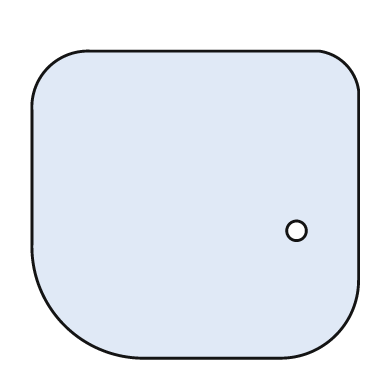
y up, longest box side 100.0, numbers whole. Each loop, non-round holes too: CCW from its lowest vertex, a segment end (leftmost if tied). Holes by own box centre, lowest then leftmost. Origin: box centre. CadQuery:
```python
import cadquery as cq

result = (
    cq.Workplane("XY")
    .moveTo(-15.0, -47.0)
    .lineTo(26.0, -47.0)
    .threePointArc((43.0, -40.0), (50.0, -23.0))
    .lineTo(50.0, 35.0)
    .threePointArc((46.0, 43.0), (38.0, 47.0))
    .lineTo(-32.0, 47.0)
    .threePointArc((-45.0, 42.0), (-50.0, 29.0))
    .lineTo(-50.0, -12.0)
    .threePointArc((-40.0, -37.0), (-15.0, -47.0))
    .close()
    .moveTo(31.0, -8.0)
    .circle(3.0)
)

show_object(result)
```